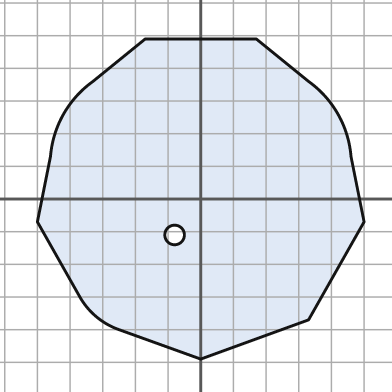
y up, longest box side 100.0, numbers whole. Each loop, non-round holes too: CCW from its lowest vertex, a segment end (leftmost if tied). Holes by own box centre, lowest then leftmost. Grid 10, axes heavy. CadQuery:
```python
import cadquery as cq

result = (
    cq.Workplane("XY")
    .moveTo(0.0, -49.0)
    .lineTo(33.0, -37.0)
    .lineTo(50.0, -7.0)
    .lineTo(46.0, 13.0)
    .threePointArc((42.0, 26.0), (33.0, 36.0))
    .lineTo(17.0, 49.0)
    .lineTo(-17.0, 49.0)
    .lineTo(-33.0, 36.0)
    .threePointArc((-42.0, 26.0), (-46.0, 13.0))
    .lineTo(-50.0, -7.0)
    .lineTo(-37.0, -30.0)
    .threePointArc((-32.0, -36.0), (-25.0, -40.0))
    .close()
    .moveTo(-8.0, -11.0)
    .circle(3.0)
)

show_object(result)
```